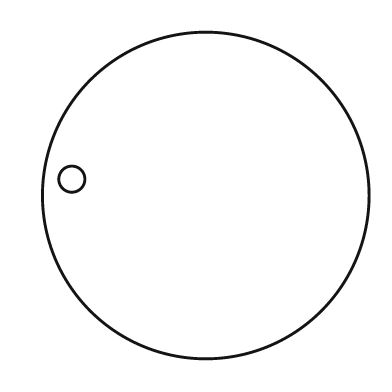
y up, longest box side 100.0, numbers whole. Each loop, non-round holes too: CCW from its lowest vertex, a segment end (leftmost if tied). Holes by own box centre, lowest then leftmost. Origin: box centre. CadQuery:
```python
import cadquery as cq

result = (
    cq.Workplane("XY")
    .moveTo(0.0, 0.0)
    .circle(50.0)
    .moveTo(-41.0, 5.0)
    .circle(4.0)
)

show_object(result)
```